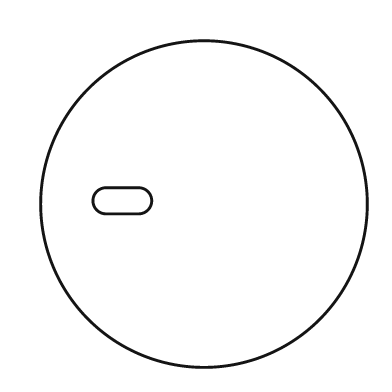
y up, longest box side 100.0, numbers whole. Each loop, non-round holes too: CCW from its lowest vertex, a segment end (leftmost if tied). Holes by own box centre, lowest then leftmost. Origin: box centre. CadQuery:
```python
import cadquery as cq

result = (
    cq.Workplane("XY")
    .moveTo(0.0, 0.0)
    .circle(50.0)
    .moveTo(-30.0, -3.0)
    .lineTo(-20.0, -3.0)
    .threePointArc((-16.0, 1.0), (-20.0, 5.0))
    .lineTo(-30.0, 5.0)
    .threePointArc((-34.0, 1.0), (-30.0, -3.0))
    .close()
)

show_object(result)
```